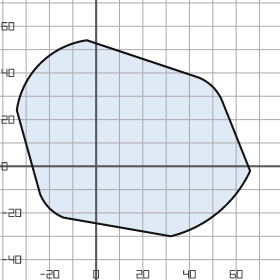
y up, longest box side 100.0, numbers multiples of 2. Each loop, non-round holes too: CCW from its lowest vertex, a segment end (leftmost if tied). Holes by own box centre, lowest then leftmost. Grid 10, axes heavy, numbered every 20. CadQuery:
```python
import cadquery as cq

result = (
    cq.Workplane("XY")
    .moveTo(32.0, -30.0)
    .threePointArc((52.0, -20.0), (66.0, -2.0))
    .lineTo(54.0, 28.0)
    .threePointArc((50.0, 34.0), (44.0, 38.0))
    .lineTo(-4.0, 54.0)
    .threePointArc((-24.0, 44.0), (-34.0, 24.0))
    .lineTo(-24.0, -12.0)
    .threePointArc((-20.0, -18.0), (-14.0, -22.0))
    .close()
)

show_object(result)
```